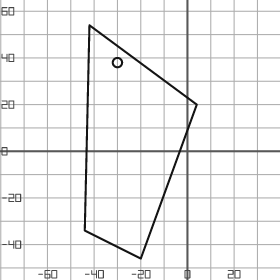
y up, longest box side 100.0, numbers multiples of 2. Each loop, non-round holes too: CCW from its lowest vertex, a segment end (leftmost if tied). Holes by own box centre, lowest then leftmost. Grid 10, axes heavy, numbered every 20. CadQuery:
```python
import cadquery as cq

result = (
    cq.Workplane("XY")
    .moveTo(-20.0, -46.0)
    .lineTo(4.0, 20.0)
    .lineTo(-42.0, 54.0)
    .lineTo(-44.0, -34.0)
    .close()
    .moveTo(-30.0, 38.0)
    .circle(2.0)
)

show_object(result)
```